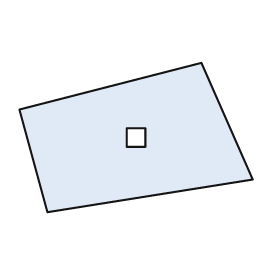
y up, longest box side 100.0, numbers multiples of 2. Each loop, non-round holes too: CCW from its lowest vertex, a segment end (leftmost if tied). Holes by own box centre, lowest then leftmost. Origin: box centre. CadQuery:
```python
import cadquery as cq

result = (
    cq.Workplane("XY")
    .moveTo(-38.0, -32.0)
    .lineTo(50.0, -18.0)
    .lineTo(28.0, 32.0)
    .lineTo(-50.0, 12.0)
    .close()
    .moveTo(-4.0, -4.0)
    .lineTo(4.0, -4.0)
    .lineTo(4.0, 4.0)
    .lineTo(-4.0, 4.0)
    .close()
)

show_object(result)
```